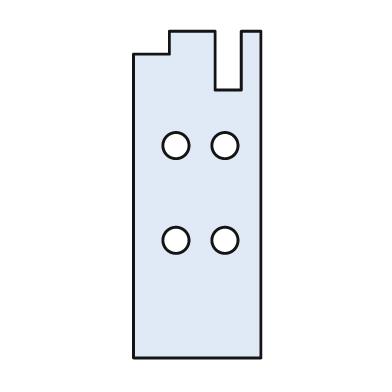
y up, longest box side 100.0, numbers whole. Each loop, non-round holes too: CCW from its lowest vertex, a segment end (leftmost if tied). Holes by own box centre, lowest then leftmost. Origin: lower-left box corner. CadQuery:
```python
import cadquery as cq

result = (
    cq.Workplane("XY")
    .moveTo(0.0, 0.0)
    .lineTo(39.0, 0.0)
    .lineTo(39.0, 100.0)
    .lineTo(33.0, 100.0)
    .lineTo(33.0, 82.0)
    .lineTo(25.0, 82.0)
    .lineTo(25.0, 100.0)
    .lineTo(11.0, 100.0)
    .lineTo(11.0, 93.0)
    .lineTo(0.0, 93.0)
    .close()
    .moveTo(13.0, 36.0)
    .circle(4.0)
    .moveTo(28.0, 36.0)
    .circle(4.0)
    .moveTo(13.0, 65.0)
    .circle(4.0)
    .moveTo(28.0, 65.0)
    .circle(4.0)
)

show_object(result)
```